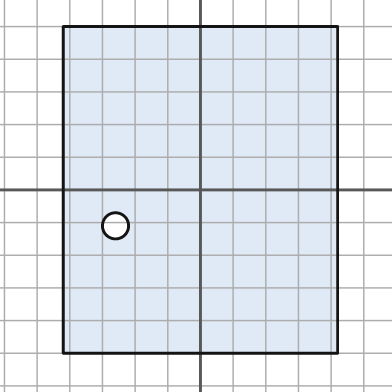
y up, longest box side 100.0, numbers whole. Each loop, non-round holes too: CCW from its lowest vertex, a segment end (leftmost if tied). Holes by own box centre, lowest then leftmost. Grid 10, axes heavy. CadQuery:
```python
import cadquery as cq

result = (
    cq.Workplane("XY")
    .moveTo(-42.0, -50.0)
    .lineTo(42.0, -50.0)
    .lineTo(42.0, 50.0)
    .lineTo(-42.0, 50.0)
    .close()
    .moveTo(-26.0, -11.0)
    .circle(4.0)
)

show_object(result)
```